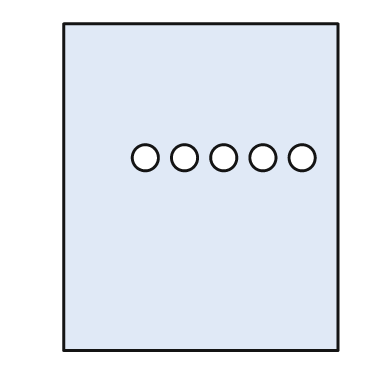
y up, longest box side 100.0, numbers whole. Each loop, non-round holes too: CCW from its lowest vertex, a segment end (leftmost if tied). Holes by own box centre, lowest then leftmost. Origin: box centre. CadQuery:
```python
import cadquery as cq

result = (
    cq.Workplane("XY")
    .moveTo(-42.0, -50.0)
    .lineTo(42.0, -50.0)
    .lineTo(42.0, 50.0)
    .lineTo(-42.0, 50.0)
    .close()
    .moveTo(-17.0, 9.0)
    .circle(4.0)
    .moveTo(-5.0, 9.0)
    .circle(4.0)
    .moveTo(7.0, 9.0)
    .circle(4.0)
    .moveTo(19.0, 9.0)
    .circle(4.0)
    .moveTo(31.0, 9.0)
    .circle(4.0)
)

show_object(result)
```